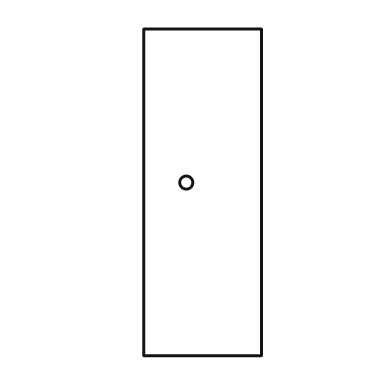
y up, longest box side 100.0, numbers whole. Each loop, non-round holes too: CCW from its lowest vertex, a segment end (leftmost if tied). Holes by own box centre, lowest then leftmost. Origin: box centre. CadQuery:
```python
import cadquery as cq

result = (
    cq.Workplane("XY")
    .moveTo(-18.0, -50.0)
    .lineTo(18.0, -50.0)
    .lineTo(18.0, 50.0)
    .lineTo(-18.0, 50.0)
    .close()
    .moveTo(-5.0, 3.0)
    .circle(2.0)
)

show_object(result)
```